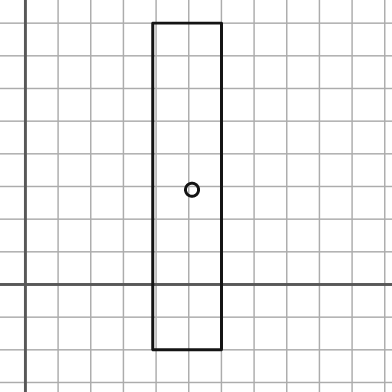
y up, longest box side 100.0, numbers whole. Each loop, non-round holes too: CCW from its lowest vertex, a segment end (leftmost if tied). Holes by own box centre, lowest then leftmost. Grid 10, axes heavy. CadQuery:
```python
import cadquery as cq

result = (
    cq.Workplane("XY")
    .moveTo(39.0, -20.0)
    .lineTo(60.0, -20.0)
    .lineTo(60.0, 80.0)
    .lineTo(39.0, 80.0)
    .close()
    .moveTo(51.0, 29.0)
    .circle(2.0)
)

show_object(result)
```